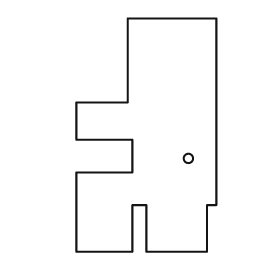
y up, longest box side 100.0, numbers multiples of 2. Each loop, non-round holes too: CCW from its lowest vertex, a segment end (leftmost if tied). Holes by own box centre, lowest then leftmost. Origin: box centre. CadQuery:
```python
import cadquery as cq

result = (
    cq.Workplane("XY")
    .moveTo(-30.0, -50.0)
    .lineTo(-6.0, -50.0)
    .lineTo(-6.0, -30.0)
    .lineTo(0.0, -30.0)
    .lineTo(0.0, -50.0)
    .lineTo(26.0, -50.0)
    .lineTo(26.0, -30.0)
    .lineTo(30.0, -30.0)
    .lineTo(30.0, 50.0)
    .lineTo(-8.0, 50.0)
    .lineTo(-8.0, 14.0)
    .lineTo(-30.0, 14.0)
    .lineTo(-30.0, -2.0)
    .lineTo(-6.0, -2.0)
    .lineTo(-6.0, -16.0)
    .lineTo(-30.0, -16.0)
    .close()
    .moveTo(18.0, -10.0)
    .circle(2.0)
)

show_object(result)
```